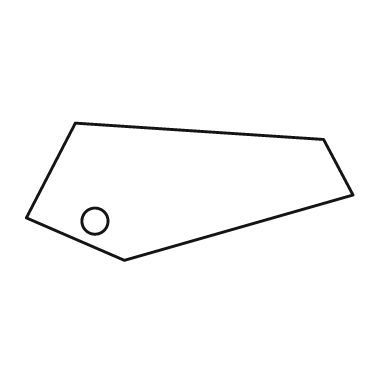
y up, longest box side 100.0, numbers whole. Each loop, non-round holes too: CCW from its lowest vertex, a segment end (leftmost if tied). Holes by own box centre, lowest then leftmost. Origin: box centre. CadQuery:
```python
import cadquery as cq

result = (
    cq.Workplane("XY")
    .moveTo(-20.0, -21.0)
    .lineTo(50.0, -1.0)
    .lineTo(41.0, 16.0)
    .lineTo(-35.0, 21.0)
    .lineTo(-50.0, -8.0)
    .close()
    .moveTo(-29.0, -9.0)
    .circle(4.0)
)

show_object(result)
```